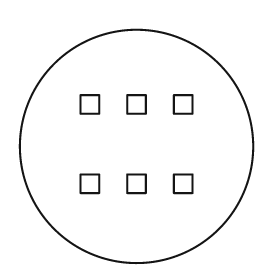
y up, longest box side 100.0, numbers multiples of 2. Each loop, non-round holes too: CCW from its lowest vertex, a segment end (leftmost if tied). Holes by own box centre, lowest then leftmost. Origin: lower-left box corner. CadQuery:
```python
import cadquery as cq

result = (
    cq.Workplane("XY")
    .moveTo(50.0, 50.0)
    .circle(50.0)
    .moveTo(26.0, 30.0)
    .lineTo(34.0, 30.0)
    .lineTo(34.0, 38.0)
    .lineTo(26.0, 38.0)
    .close()
    .moveTo(46.0, 30.0)
    .lineTo(54.0, 30.0)
    .lineTo(54.0, 38.0)
    .lineTo(46.0, 38.0)
    .close()
    .moveTo(66.0, 30.0)
    .lineTo(74.0, 30.0)
    .lineTo(74.0, 38.0)
    .lineTo(66.0, 38.0)
    .close()
    .moveTo(26.0, 64.0)
    .lineTo(34.0, 64.0)
    .lineTo(34.0, 72.0)
    .lineTo(26.0, 72.0)
    .close()
    .moveTo(46.0, 64.0)
    .lineTo(54.0, 64.0)
    .lineTo(54.0, 72.0)
    .lineTo(46.0, 72.0)
    .close()
    .moveTo(66.0, 64.0)
    .lineTo(74.0, 64.0)
    .lineTo(74.0, 72.0)
    .lineTo(66.0, 72.0)
    .close()
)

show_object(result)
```